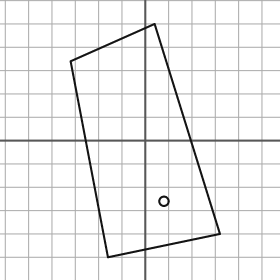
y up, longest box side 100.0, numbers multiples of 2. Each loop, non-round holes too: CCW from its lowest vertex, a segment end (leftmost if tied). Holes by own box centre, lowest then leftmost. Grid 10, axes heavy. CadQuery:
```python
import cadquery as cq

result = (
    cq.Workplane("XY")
    .moveTo(-16.0, -50.0)
    .lineTo(32.0, -40.0)
    .lineTo(4.0, 50.0)
    .lineTo(-32.0, 34.0)
    .close()
    .moveTo(8.0, -26.0)
    .circle(2.0)
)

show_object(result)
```